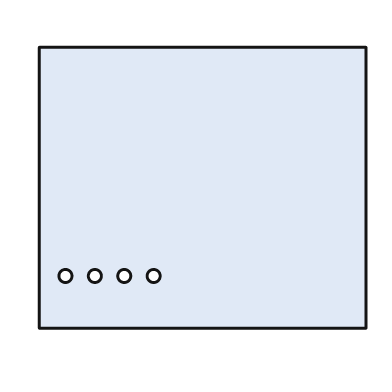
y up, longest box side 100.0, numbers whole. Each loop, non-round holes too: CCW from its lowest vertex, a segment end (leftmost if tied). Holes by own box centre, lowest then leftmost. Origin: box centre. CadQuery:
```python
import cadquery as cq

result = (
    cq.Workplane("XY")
    .moveTo(-50.0, -43.0)
    .lineTo(50.0, -43.0)
    .lineTo(50.0, 43.0)
    .lineTo(-50.0, 43.0)
    .close()
    .moveTo(-42.0, -27.0)
    .circle(2.0)
    .moveTo(-33.0, -27.0)
    .circle(2.0)
    .moveTo(-24.0, -27.0)
    .circle(2.0)
    .moveTo(-15.0, -27.0)
    .circle(2.0)
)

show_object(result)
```